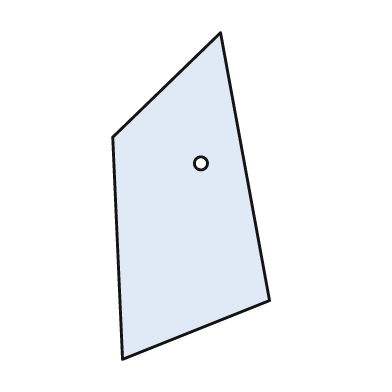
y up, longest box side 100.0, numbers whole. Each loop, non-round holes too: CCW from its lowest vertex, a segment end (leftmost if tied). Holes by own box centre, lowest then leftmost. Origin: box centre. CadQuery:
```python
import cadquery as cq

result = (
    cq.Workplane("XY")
    .moveTo(-21.0, -50.0)
    .lineTo(24.0, -32.0)
    .lineTo(9.0, 50.0)
    .lineTo(-24.0, 18.0)
    .close()
    .moveTo(3.0, 10.0)
    .circle(2.0)
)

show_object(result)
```